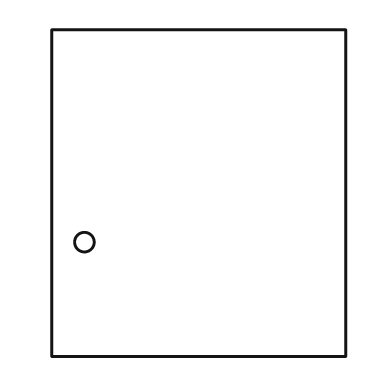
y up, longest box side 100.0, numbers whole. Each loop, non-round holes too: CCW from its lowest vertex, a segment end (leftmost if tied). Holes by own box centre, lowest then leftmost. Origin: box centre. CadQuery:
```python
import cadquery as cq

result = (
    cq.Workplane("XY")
    .moveTo(-45.0, -50.0)
    .lineTo(45.0, -50.0)
    .lineTo(45.0, 50.0)
    .lineTo(-45.0, 50.0)
    .close()
    .moveTo(-35.0, -15.0)
    .circle(3.0)
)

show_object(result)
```